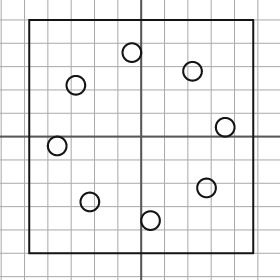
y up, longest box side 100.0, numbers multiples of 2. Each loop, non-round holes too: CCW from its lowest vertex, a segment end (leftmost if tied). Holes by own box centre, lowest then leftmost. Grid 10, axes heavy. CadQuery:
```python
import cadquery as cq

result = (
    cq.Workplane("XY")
    .moveTo(-48.0, -50.0)
    .lineTo(48.0, -50.0)
    .lineTo(48.0, 50.0)
    .lineTo(-48.0, 50.0)
    .close()
    .moveTo(4.0, -36.0)
    .circle(4.0)
    .moveTo(-22.0, -28.0)
    .circle(4.0)
    .moveTo(28.0, -22.0)
    .circle(4.0)
    .moveTo(-36.0, -4.0)
    .circle(4.0)
    .moveTo(36.0, 4.0)
    .circle(4.0)
    .moveTo(-28.0, 22.0)
    .circle(4.0)
    .moveTo(22.0, 28.0)
    .circle(4.0)
    .moveTo(-4.0, 36.0)
    .circle(4.0)
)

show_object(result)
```